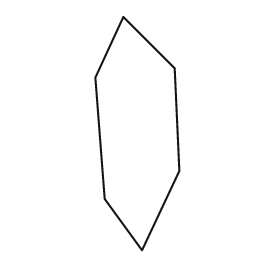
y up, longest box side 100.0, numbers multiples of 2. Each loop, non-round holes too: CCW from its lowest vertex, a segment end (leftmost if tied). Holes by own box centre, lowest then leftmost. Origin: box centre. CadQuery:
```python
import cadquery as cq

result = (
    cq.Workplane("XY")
    .moveTo(2.0, -50.0)
    .lineTo(18.0, -16.0)
    .lineTo(16.0, 28.0)
    .lineTo(-6.0, 50.0)
    .lineTo(-18.0, 24.0)
    .lineTo(-14.0, -28.0)
    .close()
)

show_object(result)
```